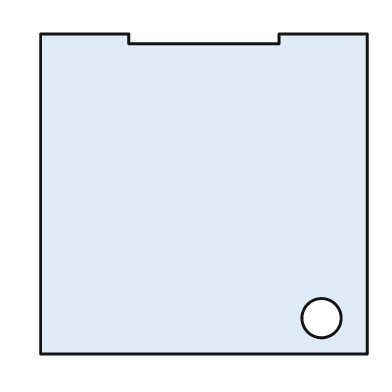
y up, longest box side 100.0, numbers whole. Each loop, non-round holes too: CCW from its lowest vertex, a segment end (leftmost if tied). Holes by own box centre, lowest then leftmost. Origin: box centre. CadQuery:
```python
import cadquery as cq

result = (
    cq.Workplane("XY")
    .moveTo(-50.0, -49.0)
    .lineTo(50.0, -49.0)
    .lineTo(50.0, 49.0)
    .lineTo(23.0, 49.0)
    .lineTo(23.0, 46.0)
    .lineTo(-23.0, 46.0)
    .lineTo(-23.0, 49.0)
    .lineTo(-50.0, 49.0)
    .close()
    .moveTo(36.0, -38.0)
    .circle(6.0)
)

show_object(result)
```